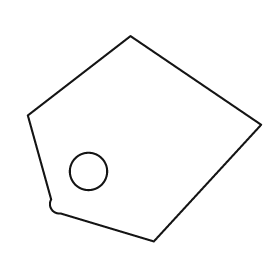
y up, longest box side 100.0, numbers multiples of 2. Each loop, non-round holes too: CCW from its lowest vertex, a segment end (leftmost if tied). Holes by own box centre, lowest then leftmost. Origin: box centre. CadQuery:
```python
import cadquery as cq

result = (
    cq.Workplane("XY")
    .moveTo(4.0, -44.0)
    .lineTo(50.0, 6.0)
    .lineTo(-6.0, 44.0)
    .lineTo(-50.0, 10.0)
    .lineTo(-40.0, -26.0)
    .threePointArc((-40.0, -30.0), (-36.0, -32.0))
    .close()
    .moveTo(-24.0, -14.0)
    .circle(8.0)
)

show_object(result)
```